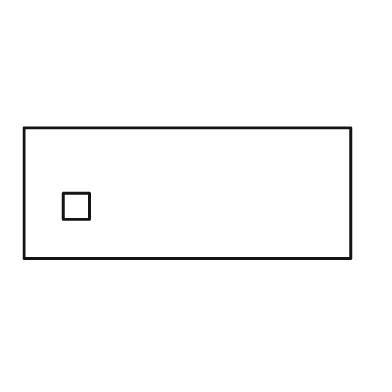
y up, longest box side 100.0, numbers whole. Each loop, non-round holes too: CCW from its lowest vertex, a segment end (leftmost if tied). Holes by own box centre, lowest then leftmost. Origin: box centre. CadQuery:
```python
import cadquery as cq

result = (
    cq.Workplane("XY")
    .moveTo(-50.0, -20.0)
    .lineTo(50.0, -20.0)
    .lineTo(50.0, 20.0)
    .lineTo(-50.0, 20.0)
    .close()
    .moveTo(-38.0, -8.0)
    .lineTo(-30.0, -8.0)
    .lineTo(-30.0, 0.0)
    .lineTo(-38.0, 0.0)
    .close()
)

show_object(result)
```